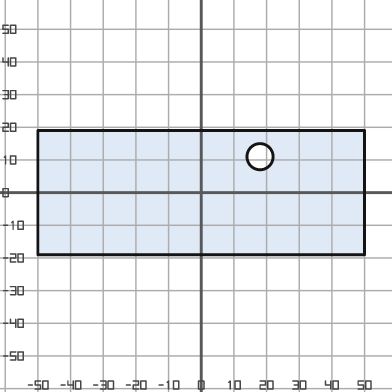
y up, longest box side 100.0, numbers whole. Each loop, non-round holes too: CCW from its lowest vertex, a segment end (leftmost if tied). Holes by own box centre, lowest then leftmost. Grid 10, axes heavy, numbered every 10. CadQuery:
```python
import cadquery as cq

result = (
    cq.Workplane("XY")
    .moveTo(-50.0, -19.0)
    .lineTo(50.0, -19.0)
    .lineTo(50.0, 19.0)
    .lineTo(-50.0, 19.0)
    .close()
    .moveTo(18.0, 11.0)
    .circle(4.0)
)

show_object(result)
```